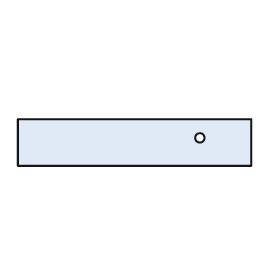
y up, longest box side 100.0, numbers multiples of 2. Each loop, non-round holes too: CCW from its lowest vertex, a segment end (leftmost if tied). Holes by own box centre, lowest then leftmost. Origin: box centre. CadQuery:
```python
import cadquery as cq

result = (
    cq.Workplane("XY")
    .moveTo(-50.0, -10.0)
    .lineTo(50.0, -10.0)
    .lineTo(50.0, 10.0)
    .lineTo(-50.0, 10.0)
    .close()
    .moveTo(28.0, 2.0)
    .circle(2.0)
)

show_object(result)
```